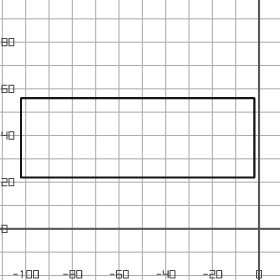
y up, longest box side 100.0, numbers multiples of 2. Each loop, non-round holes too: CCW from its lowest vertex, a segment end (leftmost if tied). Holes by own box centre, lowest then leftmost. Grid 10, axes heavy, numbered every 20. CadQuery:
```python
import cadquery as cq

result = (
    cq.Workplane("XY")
    .moveTo(-102.0, 22.0)
    .lineTo(-2.0, 22.0)
    .lineTo(-2.0, 56.0)
    .lineTo(-102.0, 56.0)
    .close()
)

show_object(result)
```